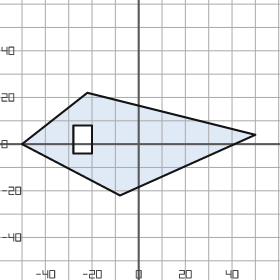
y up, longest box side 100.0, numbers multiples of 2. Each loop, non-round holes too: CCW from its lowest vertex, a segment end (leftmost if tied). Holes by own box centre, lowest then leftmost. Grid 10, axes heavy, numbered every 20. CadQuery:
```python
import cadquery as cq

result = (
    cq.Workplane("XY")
    .moveTo(-8.0, -22.0)
    .lineTo(50.0, 4.0)
    .lineTo(-22.0, 22.0)
    .lineTo(-50.0, 0.0)
    .close()
    .moveTo(-28.0, -4.0)
    .lineTo(-20.0, -4.0)
    .lineTo(-20.0, 8.0)
    .lineTo(-28.0, 8.0)
    .close()
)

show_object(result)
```